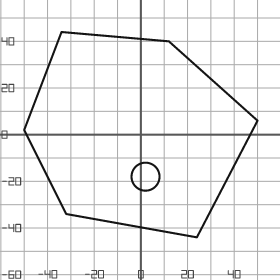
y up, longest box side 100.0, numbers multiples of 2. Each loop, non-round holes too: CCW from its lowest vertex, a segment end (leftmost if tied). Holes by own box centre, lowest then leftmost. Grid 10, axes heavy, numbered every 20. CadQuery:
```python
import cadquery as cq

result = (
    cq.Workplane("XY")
    .moveTo(24.0, -44.0)
    .lineTo(50.0, 6.0)
    .lineTo(12.0, 40.0)
    .lineTo(-34.0, 44.0)
    .lineTo(-50.0, 2.0)
    .lineTo(-32.0, -34.0)
    .close()
    .moveTo(2.0, -18.0)
    .circle(6.0)
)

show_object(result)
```